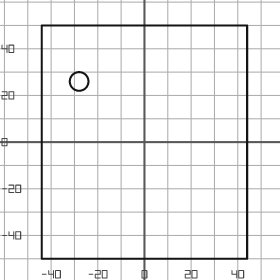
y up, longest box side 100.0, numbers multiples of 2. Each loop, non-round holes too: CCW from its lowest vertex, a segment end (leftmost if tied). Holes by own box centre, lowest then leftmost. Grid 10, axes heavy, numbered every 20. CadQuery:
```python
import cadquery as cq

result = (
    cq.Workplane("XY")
    .moveTo(-44.0, -50.0)
    .lineTo(44.0, -50.0)
    .lineTo(44.0, 50.0)
    .lineTo(-44.0, 50.0)
    .close()
    .moveTo(-28.0, 26.0)
    .circle(4.0)
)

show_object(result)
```